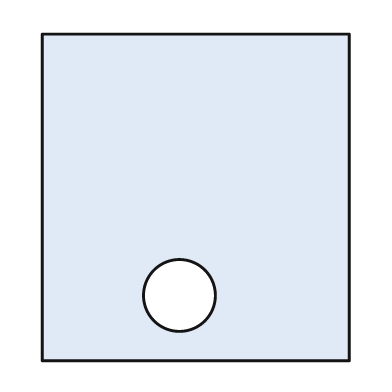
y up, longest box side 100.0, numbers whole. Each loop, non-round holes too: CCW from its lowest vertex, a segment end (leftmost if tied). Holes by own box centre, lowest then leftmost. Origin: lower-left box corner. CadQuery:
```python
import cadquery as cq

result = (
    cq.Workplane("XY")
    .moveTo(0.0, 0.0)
    .lineTo(94.0, 0.0)
    .lineTo(94.0, 100.0)
    .lineTo(0.0, 100.0)
    .close()
    .moveTo(42.0, 20.0)
    .circle(11.0)
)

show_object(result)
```